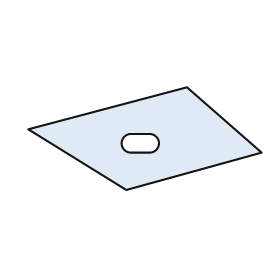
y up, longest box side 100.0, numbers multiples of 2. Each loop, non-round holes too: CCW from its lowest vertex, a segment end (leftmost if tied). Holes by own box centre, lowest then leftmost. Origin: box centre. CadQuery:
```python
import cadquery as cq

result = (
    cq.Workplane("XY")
    .moveTo(-8.0, -22.0)
    .lineTo(50.0, -6.0)
    .lineTo(18.0, 22.0)
    .lineTo(-50.0, 4.0)
    .close()
    .moveTo(-6.0, -6.0)
    .lineTo(2.0, -6.0)
    .threePointArc((6.0, -2.0), (2.0, 2.0))
    .lineTo(-6.0, 2.0)
    .threePointArc((-10.0, -2.0), (-6.0, -6.0))
    .close()
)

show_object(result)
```